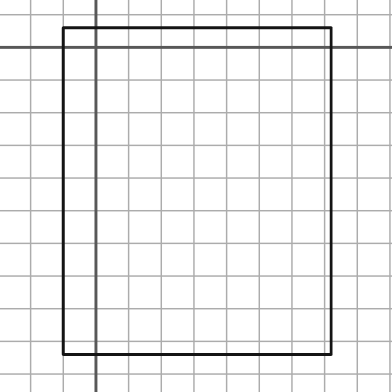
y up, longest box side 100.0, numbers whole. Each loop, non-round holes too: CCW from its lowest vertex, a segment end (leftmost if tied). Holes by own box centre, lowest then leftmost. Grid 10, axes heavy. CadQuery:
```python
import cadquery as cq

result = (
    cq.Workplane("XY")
    .moveTo(-10.0, -94.0)
    .lineTo(72.0, -94.0)
    .lineTo(72.0, 6.0)
    .lineTo(-10.0, 6.0)
    .close()
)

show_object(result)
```